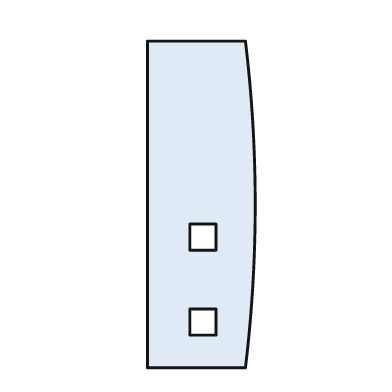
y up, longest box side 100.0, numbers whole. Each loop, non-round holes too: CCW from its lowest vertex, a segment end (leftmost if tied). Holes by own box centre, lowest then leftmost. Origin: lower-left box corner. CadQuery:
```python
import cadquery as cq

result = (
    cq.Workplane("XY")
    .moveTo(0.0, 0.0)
    .lineTo(30.0, 0.0)
    .threePointArc((33.0, 50.0), (30.0, 100.0))
    .lineTo(0.0, 100.0)
    .close()
    .moveTo(13.0, 10.0)
    .lineTo(21.0, 10.0)
    .lineTo(21.0, 18.0)
    .lineTo(13.0, 18.0)
    .close()
    .moveTo(13.0, 36.0)
    .lineTo(21.0, 36.0)
    .lineTo(21.0, 44.0)
    .lineTo(13.0, 44.0)
    .close()
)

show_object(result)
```